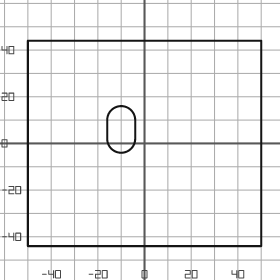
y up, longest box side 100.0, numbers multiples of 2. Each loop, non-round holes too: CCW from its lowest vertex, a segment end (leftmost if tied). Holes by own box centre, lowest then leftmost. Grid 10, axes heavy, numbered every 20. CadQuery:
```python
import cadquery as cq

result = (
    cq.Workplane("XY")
    .moveTo(-50.0, -44.0)
    .lineTo(50.0, -44.0)
    .lineTo(50.0, 44.0)
    .lineTo(-50.0, 44.0)
    .close()
    .moveTo(-16.0, 2.0)
    .threePointArc((-10.0, -4.0), (-4.0, 2.0))
    .lineTo(-4.0, 10.0)
    .threePointArc((-10.0, 16.0), (-16.0, 10.0))
    .close()
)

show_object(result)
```